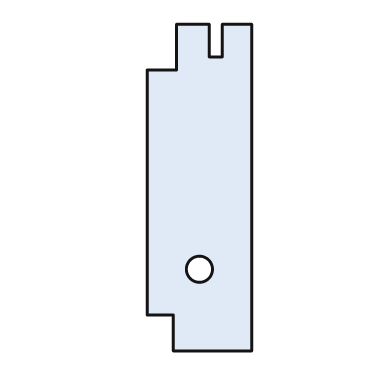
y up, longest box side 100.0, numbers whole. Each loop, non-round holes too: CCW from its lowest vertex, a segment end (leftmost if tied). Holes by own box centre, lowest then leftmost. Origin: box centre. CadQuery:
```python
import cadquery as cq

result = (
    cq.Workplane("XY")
    .moveTo(-8.0, -50.0)
    .lineTo(16.0, -50.0)
    .lineTo(16.0, 50.0)
    .lineTo(7.0, 50.0)
    .lineTo(7.0, 40.0)
    .lineTo(3.0, 40.0)
    .lineTo(3.0, 50.0)
    .lineTo(-7.0, 50.0)
    .lineTo(-7.0, 36.0)
    .lineTo(-16.0, 36.0)
    .lineTo(-16.0, -39.0)
    .lineTo(-8.0, -39.0)
    .close()
    .moveTo(0.0, -25.0)
    .circle(4.0)
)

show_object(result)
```